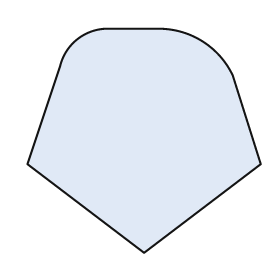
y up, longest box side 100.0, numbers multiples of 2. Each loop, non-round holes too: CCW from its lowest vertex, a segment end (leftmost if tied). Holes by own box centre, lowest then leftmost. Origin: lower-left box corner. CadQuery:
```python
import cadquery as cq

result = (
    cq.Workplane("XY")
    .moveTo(50.0, 0.0)
    .lineTo(100.0, 38.0)
    .lineTo(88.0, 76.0)
    .threePointArc((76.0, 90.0), (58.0, 96.0))
    .lineTo(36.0, 96.0)
    .threePointArc((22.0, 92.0), (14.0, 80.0))
    .lineTo(0.0, 38.0)
    .close()
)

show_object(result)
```